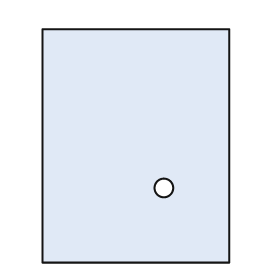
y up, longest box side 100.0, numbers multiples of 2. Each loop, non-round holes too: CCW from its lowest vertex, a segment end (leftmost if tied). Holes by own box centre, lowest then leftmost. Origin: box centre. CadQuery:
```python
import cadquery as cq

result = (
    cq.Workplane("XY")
    .moveTo(-40.0, -50.0)
    .lineTo(40.0, -50.0)
    .lineTo(40.0, 50.0)
    .lineTo(-40.0, 50.0)
    .close()
    .moveTo(12.0, -18.0)
    .circle(4.0)
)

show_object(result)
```